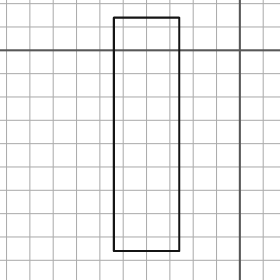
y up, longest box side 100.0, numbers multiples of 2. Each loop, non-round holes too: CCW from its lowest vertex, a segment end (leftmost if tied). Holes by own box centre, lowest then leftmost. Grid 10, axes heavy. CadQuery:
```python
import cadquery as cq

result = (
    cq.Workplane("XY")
    .moveTo(-54.0, -86.0)
    .lineTo(-26.0, -86.0)
    .lineTo(-26.0, 14.0)
    .lineTo(-54.0, 14.0)
    .close()
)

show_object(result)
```